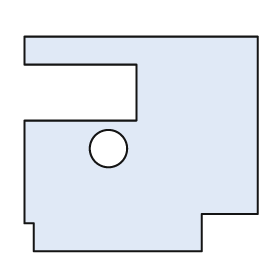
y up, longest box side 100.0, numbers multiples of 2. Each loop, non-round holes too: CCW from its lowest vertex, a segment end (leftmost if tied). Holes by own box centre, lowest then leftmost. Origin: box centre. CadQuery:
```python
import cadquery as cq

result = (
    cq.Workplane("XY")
    .moveTo(-46.0, -46.0)
    .lineTo(26.0, -46.0)
    .lineTo(26.0, -30.0)
    .lineTo(50.0, -30.0)
    .lineTo(50.0, 46.0)
    .lineTo(-50.0, 46.0)
    .lineTo(-50.0, 34.0)
    .lineTo(-2.0, 34.0)
    .lineTo(-2.0, 10.0)
    .lineTo(-50.0, 10.0)
    .lineTo(-50.0, -34.0)
    .lineTo(-46.0, -34.0)
    .close()
    .moveTo(-14.0, -2.0)
    .circle(8.0)
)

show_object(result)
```